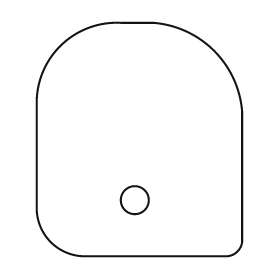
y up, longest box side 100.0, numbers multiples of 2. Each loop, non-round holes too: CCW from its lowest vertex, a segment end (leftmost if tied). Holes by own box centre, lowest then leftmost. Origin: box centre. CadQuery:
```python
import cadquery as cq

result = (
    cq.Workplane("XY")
    .moveTo(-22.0, -50.0)
    .lineTo(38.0, -50.0)
    .threePointArc((42.0, -48.0), (44.0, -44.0))
    .lineTo(44.0, 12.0)
    .threePointArc((32.0, 38.0), (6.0, 50.0))
    .lineTo(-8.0, 50.0)
    .threePointArc((-34.0, 40.0), (-44.0, 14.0))
    .lineTo(-44.0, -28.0)
    .threePointArc((-38.0, -44.0), (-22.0, -50.0))
    .close()
    .moveTo(-2.0, -26.0)
    .circle(6.0)
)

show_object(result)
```